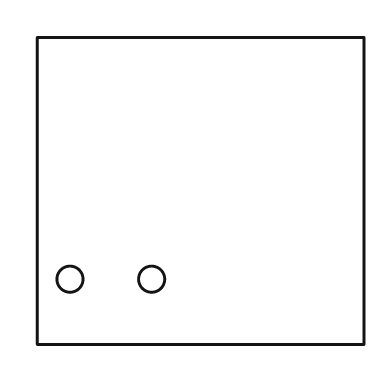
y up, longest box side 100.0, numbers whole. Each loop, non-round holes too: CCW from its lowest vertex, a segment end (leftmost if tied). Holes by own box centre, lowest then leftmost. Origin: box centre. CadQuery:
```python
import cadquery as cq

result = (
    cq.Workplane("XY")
    .moveTo(-50.0, -47.0)
    .lineTo(50.0, -47.0)
    .lineTo(50.0, 47.0)
    .lineTo(-50.0, 47.0)
    .close()
    .moveTo(-40.0, -27.0)
    .circle(4.0)
    .moveTo(-15.0, -27.0)
    .circle(4.0)
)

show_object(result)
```